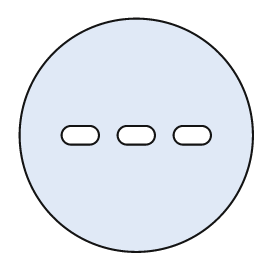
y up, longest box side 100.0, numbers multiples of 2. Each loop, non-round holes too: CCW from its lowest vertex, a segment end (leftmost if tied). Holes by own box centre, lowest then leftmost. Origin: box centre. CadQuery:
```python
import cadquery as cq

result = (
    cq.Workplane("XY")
    .moveTo(0.0, 0.0)
    .circle(50.0)
    .moveTo(-28.0, -4.0)
    .lineTo(-20.0, -4.0)
    .threePointArc((-16.0, 0.0), (-20.0, 4.0))
    .lineTo(-28.0, 4.0)
    .threePointArc((-32.0, 0.0), (-28.0, -4.0))
    .close()
    .moveTo(-4.0, -4.0)
    .lineTo(4.0, -4.0)
    .threePointArc((8.0, 0.0), (4.0, 4.0))
    .lineTo(-4.0, 4.0)
    .threePointArc((-8.0, 0.0), (-4.0, -4.0))
    .close()
    .moveTo(20.0, -4.0)
    .lineTo(28.0, -4.0)
    .threePointArc((32.0, 0.0), (28.0, 4.0))
    .lineTo(20.0, 4.0)
    .threePointArc((16.0, 0.0), (20.0, -4.0))
    .close()
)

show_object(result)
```